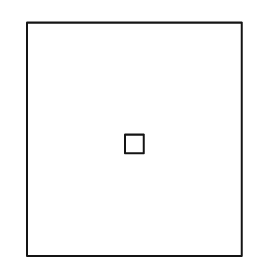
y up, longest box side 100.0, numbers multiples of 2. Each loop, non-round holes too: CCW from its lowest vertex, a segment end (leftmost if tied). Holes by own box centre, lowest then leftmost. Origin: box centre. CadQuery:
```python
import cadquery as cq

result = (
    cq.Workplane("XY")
    .moveTo(-46.0, -50.0)
    .lineTo(46.0, -50.0)
    .lineTo(46.0, 50.0)
    .lineTo(-46.0, 50.0)
    .close()
    .moveTo(-4.0, -6.0)
    .lineTo(4.0, -6.0)
    .lineTo(4.0, 2.0)
    .lineTo(-4.0, 2.0)
    .close()
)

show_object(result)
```